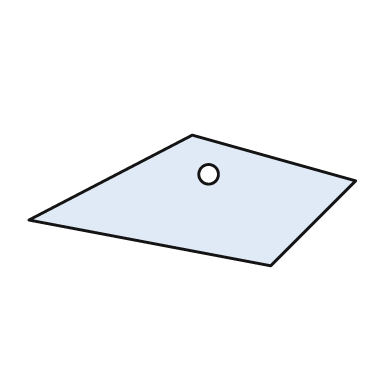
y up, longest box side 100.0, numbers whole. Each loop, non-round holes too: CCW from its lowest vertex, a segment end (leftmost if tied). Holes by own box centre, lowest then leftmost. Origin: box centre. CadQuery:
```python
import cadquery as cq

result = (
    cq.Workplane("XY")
    .moveTo(24.0, -20.0)
    .lineTo(50.0, 6.0)
    .lineTo(0.0, 20.0)
    .lineTo(-50.0, -6.0)
    .close()
    .moveTo(5.0, 8.0)
    .circle(3.0)
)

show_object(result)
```